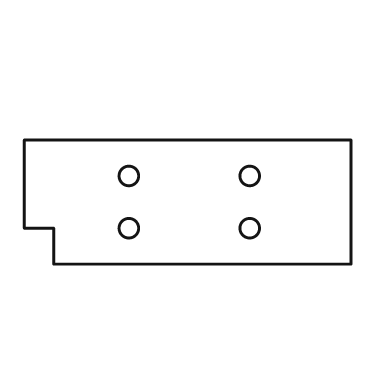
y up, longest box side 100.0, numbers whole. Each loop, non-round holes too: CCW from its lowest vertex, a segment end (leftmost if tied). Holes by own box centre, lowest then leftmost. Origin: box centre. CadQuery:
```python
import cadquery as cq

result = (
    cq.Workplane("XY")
    .moveTo(-41.0, -19.0)
    .lineTo(50.0, -19.0)
    .lineTo(50.0, 19.0)
    .lineTo(-50.0, 19.0)
    .lineTo(-50.0, -8.0)
    .lineTo(-41.0, -8.0)
    .close()
    .moveTo(-18.0, -8.0)
    .circle(3.0)
    .moveTo(19.0, -8.0)
    .circle(3.0)
    .moveTo(-18.0, 8.0)
    .circle(3.0)
    .moveTo(19.0, 8.0)
    .circle(3.0)
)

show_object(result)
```